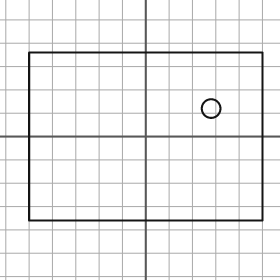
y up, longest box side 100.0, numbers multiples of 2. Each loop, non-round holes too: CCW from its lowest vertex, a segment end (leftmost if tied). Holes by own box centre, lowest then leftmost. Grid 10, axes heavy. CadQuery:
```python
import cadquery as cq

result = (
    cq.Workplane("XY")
    .moveTo(-50.0, -36.0)
    .lineTo(50.0, -36.0)
    .lineTo(50.0, 36.0)
    .lineTo(-50.0, 36.0)
    .close()
    .moveTo(28.0, 12.0)
    .circle(4.0)
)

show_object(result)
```